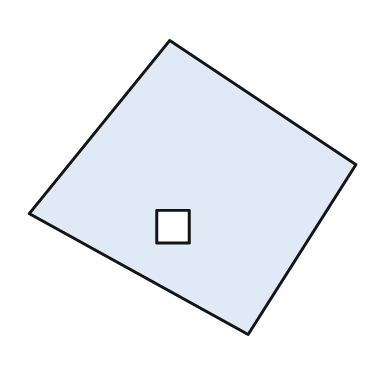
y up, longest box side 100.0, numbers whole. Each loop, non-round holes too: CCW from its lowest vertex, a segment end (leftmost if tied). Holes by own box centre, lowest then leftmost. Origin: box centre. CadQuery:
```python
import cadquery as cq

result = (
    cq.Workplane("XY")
    .moveTo(17.0, -45.0)
    .lineTo(50.0, 7.0)
    .lineTo(-7.0, 45.0)
    .lineTo(-50.0, -8.0)
    .close()
    .moveTo(-11.0, -17.0)
    .lineTo(-1.0, -17.0)
    .lineTo(-1.0, -7.0)
    .lineTo(-11.0, -7.0)
    .close()
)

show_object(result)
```